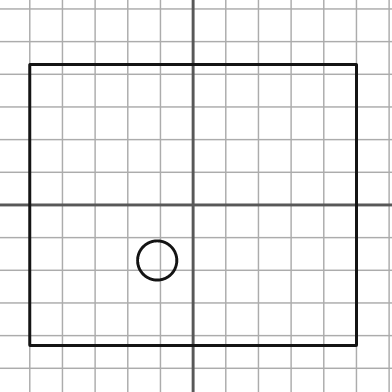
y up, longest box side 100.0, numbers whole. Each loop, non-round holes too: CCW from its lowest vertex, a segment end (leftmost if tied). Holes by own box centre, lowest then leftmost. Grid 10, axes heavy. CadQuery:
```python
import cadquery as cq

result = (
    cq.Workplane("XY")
    .moveTo(-50.0, -43.0)
    .lineTo(50.0, -43.0)
    .lineTo(50.0, 43.0)
    .lineTo(-50.0, 43.0)
    .close()
    .moveTo(-11.0, -17.0)
    .circle(6.0)
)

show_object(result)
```